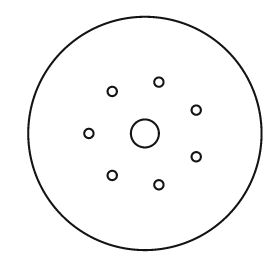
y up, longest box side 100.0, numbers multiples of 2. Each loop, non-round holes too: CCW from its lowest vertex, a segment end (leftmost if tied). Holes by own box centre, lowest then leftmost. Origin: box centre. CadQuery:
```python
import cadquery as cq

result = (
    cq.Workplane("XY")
    .moveTo(0.0, 0.0)
    .circle(50.0)
    .moveTo(6.0, -22.0)
    .circle(2.0)
    .moveTo(-14.0, -18.0)
    .circle(2.0)
    .moveTo(22.0, -10.0)
    .circle(2.0)
    .moveTo(-24.0, 0.0)
    .circle(2.0)
    .moveTo(0.0, 0.0)
    .circle(6.0)
    .moveTo(22.0, 10.0)
    .circle(2.0)
    .moveTo(-14.0, 18.0)
    .circle(2.0)
    .moveTo(6.0, 22.0)
    .circle(2.0)
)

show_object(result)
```